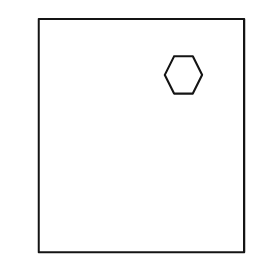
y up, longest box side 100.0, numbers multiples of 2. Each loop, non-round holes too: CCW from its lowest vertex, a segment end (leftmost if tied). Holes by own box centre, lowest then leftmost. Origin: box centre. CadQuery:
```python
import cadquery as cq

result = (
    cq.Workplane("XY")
    .moveTo(-44.0, -50.0)
    .lineTo(44.0, -50.0)
    .lineTo(44.0, 50.0)
    .lineTo(-44.0, 50.0)
    .close()
    .moveTo(14.0, 18.0)
    .lineTo(22.0, 18.0)
    .lineTo(26.0, 26.0)
    .lineTo(22.0, 34.0)
    .lineTo(14.0, 34.0)
    .lineTo(10.0, 26.0)
    .close()
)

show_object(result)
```